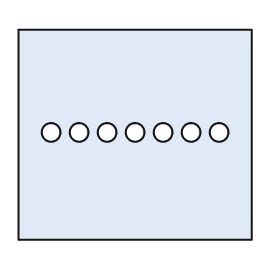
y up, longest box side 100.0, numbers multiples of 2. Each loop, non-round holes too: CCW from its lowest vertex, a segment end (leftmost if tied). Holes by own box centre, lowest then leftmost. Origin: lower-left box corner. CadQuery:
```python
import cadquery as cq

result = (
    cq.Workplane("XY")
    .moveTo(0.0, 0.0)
    .lineTo(100.0, 0.0)
    .lineTo(100.0, 90.0)
    .lineTo(0.0, 90.0)
    .close()
    .moveTo(14.0, 46.0)
    .circle(4.0)
    .moveTo(26.0, 46.0)
    .circle(4.0)
    .moveTo(38.0, 46.0)
    .circle(4.0)
    .moveTo(50.0, 46.0)
    .circle(4.0)
    .moveTo(62.0, 46.0)
    .circle(4.0)
    .moveTo(74.0, 46.0)
    .circle(4.0)
    .moveTo(86.0, 46.0)
    .circle(4.0)
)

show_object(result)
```